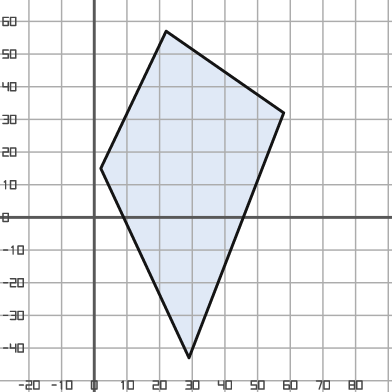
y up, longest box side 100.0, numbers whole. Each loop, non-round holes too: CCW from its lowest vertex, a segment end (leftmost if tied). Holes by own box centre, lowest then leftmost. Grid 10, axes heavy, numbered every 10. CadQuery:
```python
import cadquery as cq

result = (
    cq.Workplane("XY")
    .moveTo(29.0, -43.0)
    .lineTo(58.0, 32.0)
    .lineTo(22.0, 57.0)
    .lineTo(2.0, 15.0)
    .close()
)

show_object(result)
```